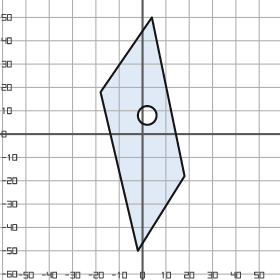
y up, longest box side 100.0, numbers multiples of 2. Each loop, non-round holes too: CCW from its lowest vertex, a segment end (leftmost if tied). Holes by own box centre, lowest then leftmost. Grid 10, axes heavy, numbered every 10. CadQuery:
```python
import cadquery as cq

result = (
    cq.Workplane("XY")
    .moveTo(-2.0, -50.0)
    .lineTo(18.0, -18.0)
    .lineTo(4.0, 50.0)
    .lineTo(-18.0, 18.0)
    .close()
    .moveTo(2.0, 8.0)
    .circle(4.0)
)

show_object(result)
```